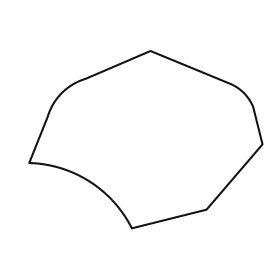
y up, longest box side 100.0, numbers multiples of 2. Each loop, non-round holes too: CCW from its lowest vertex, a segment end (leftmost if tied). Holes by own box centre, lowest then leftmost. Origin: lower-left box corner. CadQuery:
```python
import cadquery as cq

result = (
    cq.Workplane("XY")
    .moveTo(44.0, 0.0)
    .lineTo(76.0, 8.0)
    .lineTo(100.0, 36.0)
    .lineTo(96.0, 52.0)
    .threePointArc((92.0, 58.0), (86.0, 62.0))
    .lineTo(52.0, 76.0)
    .lineTo(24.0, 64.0)
    .threePointArc((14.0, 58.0), (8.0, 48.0))
    .lineTo(0.0, 28.0)
    .threePointArc((26.0, 20.0), (44.0, 0.0))
    .close()
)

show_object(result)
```